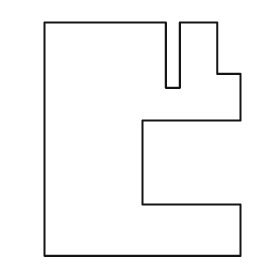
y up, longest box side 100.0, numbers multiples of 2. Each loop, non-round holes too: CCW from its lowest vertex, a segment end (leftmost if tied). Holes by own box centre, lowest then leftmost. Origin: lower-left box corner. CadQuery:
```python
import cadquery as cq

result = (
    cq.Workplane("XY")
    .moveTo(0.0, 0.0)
    .lineTo(84.0, 0.0)
    .lineTo(84.0, 22.0)
    .lineTo(42.0, 22.0)
    .lineTo(42.0, 58.0)
    .lineTo(84.0, 58.0)
    .lineTo(84.0, 78.0)
    .lineTo(74.0, 78.0)
    .lineTo(74.0, 100.0)
    .lineTo(58.0, 100.0)
    .lineTo(58.0, 72.0)
    .lineTo(52.0, 72.0)
    .lineTo(52.0, 100.0)
    .lineTo(0.0, 100.0)
    .close()
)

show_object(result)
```